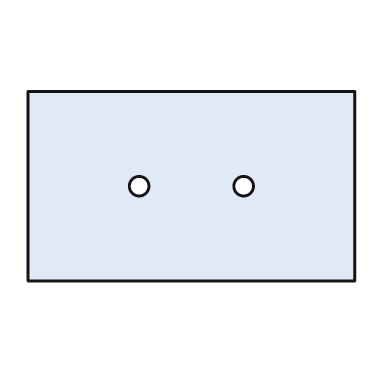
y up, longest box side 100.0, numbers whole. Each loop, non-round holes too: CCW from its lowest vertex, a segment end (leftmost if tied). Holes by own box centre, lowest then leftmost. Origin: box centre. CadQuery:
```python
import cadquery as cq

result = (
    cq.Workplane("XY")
    .moveTo(-50.0, -29.0)
    .lineTo(50.0, -29.0)
    .lineTo(50.0, 29.0)
    .lineTo(-50.0, 29.0)
    .close()
    .moveTo(-16.0, 0.0)
    .circle(3.0)
    .moveTo(16.0, 0.0)
    .circle(3.0)
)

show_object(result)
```